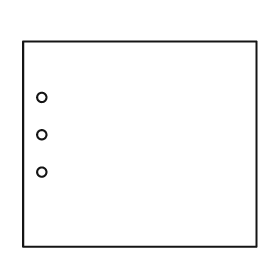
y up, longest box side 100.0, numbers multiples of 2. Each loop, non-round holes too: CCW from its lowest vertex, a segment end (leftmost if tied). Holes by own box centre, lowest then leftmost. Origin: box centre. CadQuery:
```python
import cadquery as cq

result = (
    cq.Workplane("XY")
    .moveTo(-50.0, -44.0)
    .lineTo(50.0, -44.0)
    .lineTo(50.0, 44.0)
    .lineTo(-50.0, 44.0)
    .close()
    .moveTo(-42.0, -12.0)
    .circle(2.0)
    .moveTo(-42.0, 4.0)
    .circle(2.0)
    .moveTo(-42.0, 20.0)
    .circle(2.0)
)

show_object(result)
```